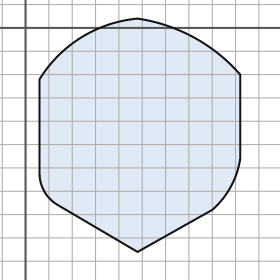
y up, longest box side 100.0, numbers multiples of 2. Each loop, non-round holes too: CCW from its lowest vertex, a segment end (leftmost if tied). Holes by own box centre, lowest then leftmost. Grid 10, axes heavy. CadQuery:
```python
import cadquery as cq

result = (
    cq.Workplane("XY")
    .moveTo(48.0, -96.0)
    .lineTo(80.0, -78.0)
    .threePointArc((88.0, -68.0), (92.0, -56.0))
    .lineTo(92.0, -20.0)
    .threePointArc((72.0, -4.0), (48.0, 4.0))
    .threePointArc((24.0, -4.0), (6.0, -22.0))
    .lineTo(6.0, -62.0)
    .threePointArc((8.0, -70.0), (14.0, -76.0))
    .close()
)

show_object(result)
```